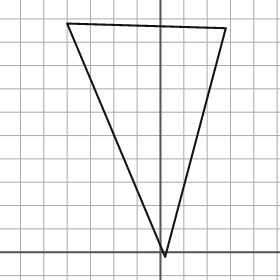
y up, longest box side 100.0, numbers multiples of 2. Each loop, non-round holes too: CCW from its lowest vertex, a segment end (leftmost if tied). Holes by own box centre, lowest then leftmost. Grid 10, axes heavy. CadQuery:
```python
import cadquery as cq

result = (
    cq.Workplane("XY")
    .moveTo(2.0, -2.0)
    .lineTo(28.0, 96.0)
    .lineTo(-40.0, 98.0)
    .close()
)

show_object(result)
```